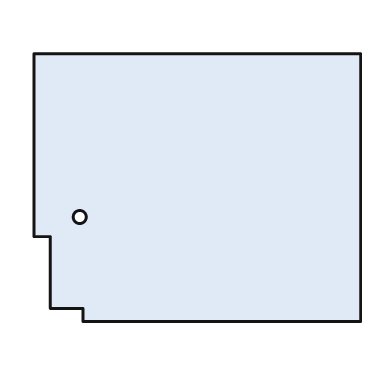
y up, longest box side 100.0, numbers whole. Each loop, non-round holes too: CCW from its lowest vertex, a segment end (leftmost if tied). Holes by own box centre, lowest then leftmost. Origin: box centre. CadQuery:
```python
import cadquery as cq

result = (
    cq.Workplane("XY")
    .moveTo(-35.0, -41.0)
    .lineTo(50.0, -41.0)
    .lineTo(50.0, 41.0)
    .lineTo(-50.0, 41.0)
    .lineTo(-50.0, -15.0)
    .lineTo(-45.0, -15.0)
    .lineTo(-45.0, -37.0)
    .lineTo(-35.0, -37.0)
    .close()
    .moveTo(-36.0, -9.0)
    .circle(2.0)
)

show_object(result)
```